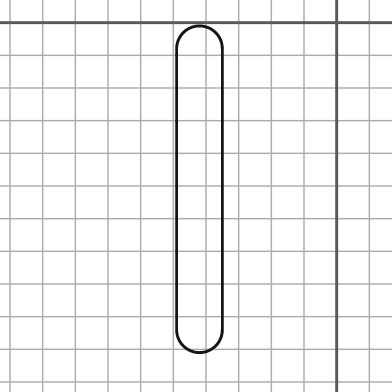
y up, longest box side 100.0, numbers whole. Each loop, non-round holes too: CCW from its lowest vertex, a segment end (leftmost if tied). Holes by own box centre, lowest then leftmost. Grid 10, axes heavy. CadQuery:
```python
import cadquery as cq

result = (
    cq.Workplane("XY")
    .moveTo(-49.0, -94.0)
    .threePointArc((-42.0, -101.0), (-35.0, -94.0))
    .lineTo(-35.0, -8.0)
    .threePointArc((-42.0, -1.0), (-49.0, -8.0))
    .close()
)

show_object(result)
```